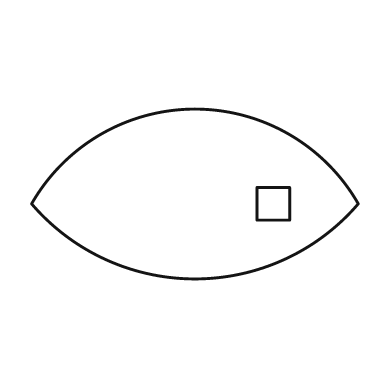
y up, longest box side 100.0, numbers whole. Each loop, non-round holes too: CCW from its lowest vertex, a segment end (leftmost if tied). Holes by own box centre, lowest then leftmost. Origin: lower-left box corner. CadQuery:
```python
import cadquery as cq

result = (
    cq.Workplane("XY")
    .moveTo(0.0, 23.0)
    .threePointArc((50.0, 0.0), (100.0, 23.0))
    .threePointArc((50.0, 52.0), (0.0, 23.0))
    .close()
    .moveTo(69.0, 18.0)
    .lineTo(79.0, 18.0)
    .lineTo(79.0, 28.0)
    .lineTo(69.0, 28.0)
    .close()
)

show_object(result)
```